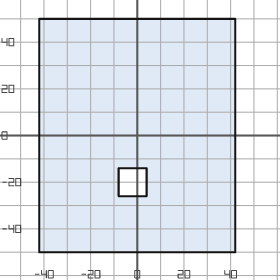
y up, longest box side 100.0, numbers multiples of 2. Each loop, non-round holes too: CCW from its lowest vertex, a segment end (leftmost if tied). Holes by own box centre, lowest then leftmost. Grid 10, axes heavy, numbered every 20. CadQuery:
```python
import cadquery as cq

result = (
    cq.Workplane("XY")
    .moveTo(-42.0, -50.0)
    .lineTo(42.0, -50.0)
    .lineTo(42.0, 50.0)
    .lineTo(-42.0, 50.0)
    .close()
    .moveTo(-8.0, -26.0)
    .lineTo(4.0, -26.0)
    .lineTo(4.0, -14.0)
    .lineTo(-8.0, -14.0)
    .close()
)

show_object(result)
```